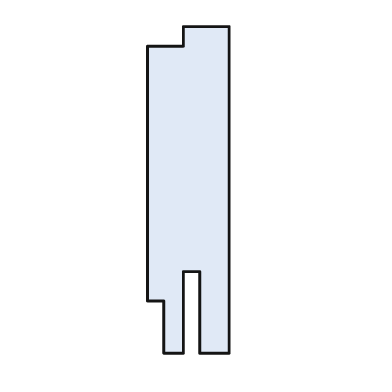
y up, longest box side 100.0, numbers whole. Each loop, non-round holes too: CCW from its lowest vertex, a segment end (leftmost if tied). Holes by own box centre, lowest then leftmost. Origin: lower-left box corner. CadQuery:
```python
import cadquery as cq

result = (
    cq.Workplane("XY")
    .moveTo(5.0, 0.0)
    .lineTo(11.0, 0.0)
    .lineTo(11.0, 25.0)
    .lineTo(16.0, 25.0)
    .lineTo(16.0, 0.0)
    .lineTo(25.0, 0.0)
    .lineTo(25.0, 100.0)
    .lineTo(11.0, 100.0)
    .lineTo(11.0, 94.0)
    .lineTo(0.0, 94.0)
    .lineTo(0.0, 16.0)
    .lineTo(5.0, 16.0)
    .close()
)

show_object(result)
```